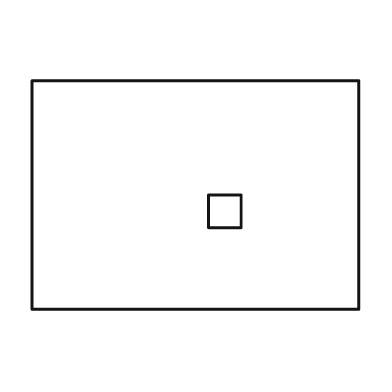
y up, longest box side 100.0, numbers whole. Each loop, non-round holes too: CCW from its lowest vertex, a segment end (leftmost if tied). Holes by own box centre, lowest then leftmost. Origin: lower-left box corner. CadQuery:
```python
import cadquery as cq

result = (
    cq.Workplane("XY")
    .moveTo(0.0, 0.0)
    .lineTo(100.0, 0.0)
    .lineTo(100.0, 70.0)
    .lineTo(0.0, 70.0)
    .close()
    .moveTo(54.0, 25.0)
    .lineTo(64.0, 25.0)
    .lineTo(64.0, 35.0)
    .lineTo(54.0, 35.0)
    .close()
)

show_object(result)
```